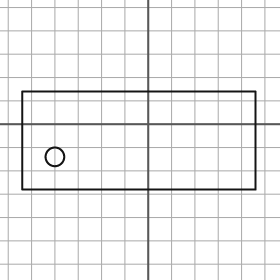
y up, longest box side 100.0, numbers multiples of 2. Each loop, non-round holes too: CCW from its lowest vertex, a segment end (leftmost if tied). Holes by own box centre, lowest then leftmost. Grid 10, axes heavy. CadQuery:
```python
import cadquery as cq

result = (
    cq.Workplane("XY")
    .moveTo(-54.0, -28.0)
    .lineTo(46.0, -28.0)
    .lineTo(46.0, 14.0)
    .lineTo(-54.0, 14.0)
    .close()
    .moveTo(-40.0, -14.0)
    .circle(4.0)
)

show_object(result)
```